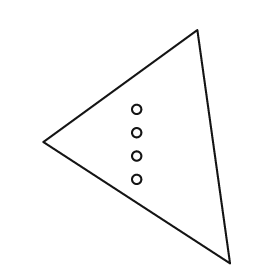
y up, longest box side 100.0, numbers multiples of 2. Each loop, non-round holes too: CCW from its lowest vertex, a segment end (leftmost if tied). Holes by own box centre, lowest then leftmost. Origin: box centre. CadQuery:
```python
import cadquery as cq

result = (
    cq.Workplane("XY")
    .moveTo(40.0, -50.0)
    .lineTo(26.0, 50.0)
    .lineTo(-40.0, 2.0)
    .close()
    .moveTo(0.0, -14.0)
    .circle(2.0)
    .moveTo(0.0, -4.0)
    .circle(2.0)
    .moveTo(0.0, 6.0)
    .circle(2.0)
    .moveTo(0.0, 16.0)
    .circle(2.0)
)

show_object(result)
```